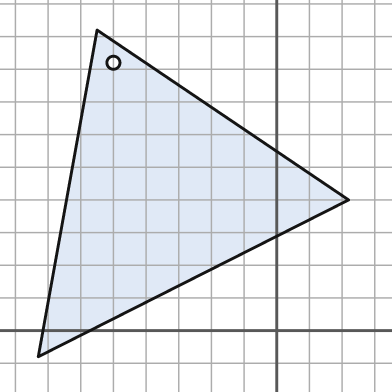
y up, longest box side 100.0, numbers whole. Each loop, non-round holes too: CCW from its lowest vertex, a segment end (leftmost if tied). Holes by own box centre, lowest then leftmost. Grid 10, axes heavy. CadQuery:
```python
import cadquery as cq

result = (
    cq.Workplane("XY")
    .moveTo(-73.0, -8.0)
    .lineTo(22.0, 40.0)
    .lineTo(-55.0, 92.0)
    .close()
    .moveTo(-50.0, 82.0)
    .circle(2.0)
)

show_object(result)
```